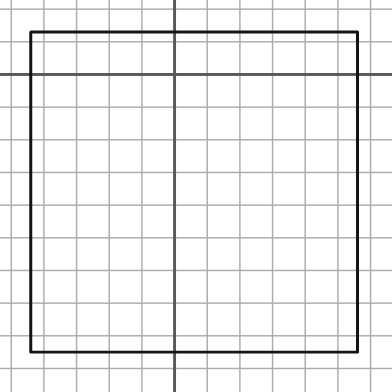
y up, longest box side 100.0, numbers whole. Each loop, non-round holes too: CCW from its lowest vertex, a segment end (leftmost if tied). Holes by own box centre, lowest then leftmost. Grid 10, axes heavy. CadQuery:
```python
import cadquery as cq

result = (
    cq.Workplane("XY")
    .moveTo(-44.0, -85.0)
    .lineTo(56.0, -85.0)
    .lineTo(56.0, 13.0)
    .lineTo(-44.0, 13.0)
    .close()
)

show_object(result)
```